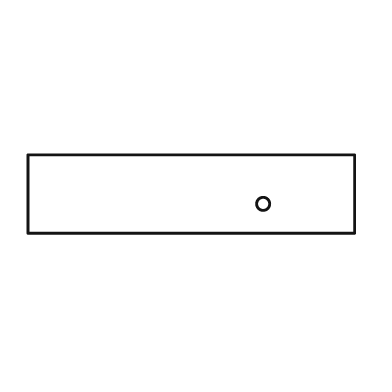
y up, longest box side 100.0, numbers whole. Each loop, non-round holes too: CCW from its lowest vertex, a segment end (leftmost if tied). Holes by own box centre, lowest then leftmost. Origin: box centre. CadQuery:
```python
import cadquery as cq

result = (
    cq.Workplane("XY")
    .moveTo(-50.0, -12.0)
    .lineTo(50.0, -12.0)
    .lineTo(50.0, 12.0)
    .lineTo(-50.0, 12.0)
    .close()
    .moveTo(22.0, -3.0)
    .circle(2.0)
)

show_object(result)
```